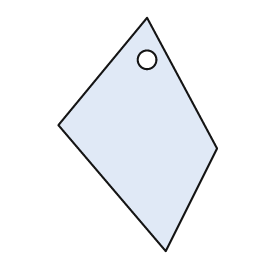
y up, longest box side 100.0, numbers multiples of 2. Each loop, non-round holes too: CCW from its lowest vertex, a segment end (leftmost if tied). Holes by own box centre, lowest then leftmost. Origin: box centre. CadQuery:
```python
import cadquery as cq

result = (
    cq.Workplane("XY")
    .moveTo(12.0, -50.0)
    .lineTo(34.0, -6.0)
    .lineTo(4.0, 50.0)
    .lineTo(-34.0, 4.0)
    .close()
    .moveTo(4.0, 32.0)
    .circle(4.0)
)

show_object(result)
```